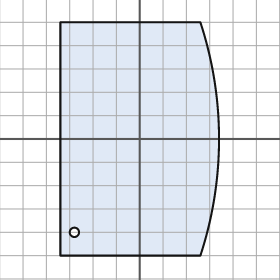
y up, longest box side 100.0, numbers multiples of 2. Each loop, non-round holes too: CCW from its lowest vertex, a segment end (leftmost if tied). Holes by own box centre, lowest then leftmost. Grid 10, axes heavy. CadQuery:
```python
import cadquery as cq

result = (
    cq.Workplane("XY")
    .moveTo(-34.0, -50.0)
    .lineTo(26.0, -50.0)
    .threePointArc((34.0, 0.0), (26.0, 50.0))
    .lineTo(-34.0, 50.0)
    .close()
    .moveTo(-28.0, -40.0)
    .circle(2.0)
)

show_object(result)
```